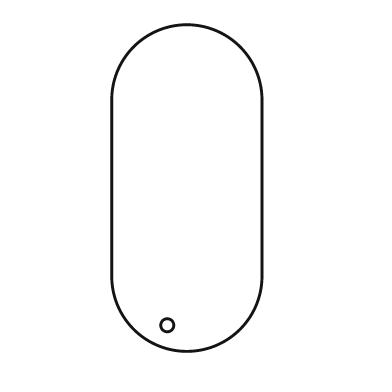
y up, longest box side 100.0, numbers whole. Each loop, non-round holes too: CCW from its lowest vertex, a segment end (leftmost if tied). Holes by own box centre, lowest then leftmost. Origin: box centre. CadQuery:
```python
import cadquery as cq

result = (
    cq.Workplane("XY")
    .moveTo(-23.0, -27.0)
    .threePointArc((0.0, -50.0), (23.0, -27.0))
    .lineTo(23.0, 27.0)
    .threePointArc((0.0, 50.0), (-23.0, 27.0))
    .close()
    .moveTo(-6.0, -42.0)
    .circle(2.0)
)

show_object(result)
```